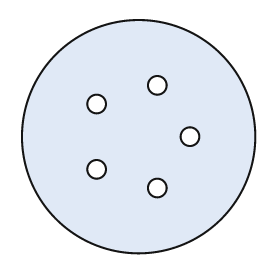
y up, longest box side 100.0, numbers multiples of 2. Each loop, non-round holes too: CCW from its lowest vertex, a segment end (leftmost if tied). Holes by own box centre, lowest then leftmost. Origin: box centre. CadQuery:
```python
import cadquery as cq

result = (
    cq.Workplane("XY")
    .moveTo(0.0, 0.0)
    .circle(50.0)
    .moveTo(8.0, -22.0)
    .circle(4.0)
    .moveTo(-18.0, -14.0)
    .circle(4.0)
    .moveTo(22.0, 0.0)
    .circle(4.0)
    .moveTo(-18.0, 14.0)
    .circle(4.0)
    .moveTo(8.0, 22.0)
    .circle(4.0)
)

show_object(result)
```